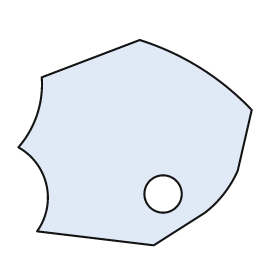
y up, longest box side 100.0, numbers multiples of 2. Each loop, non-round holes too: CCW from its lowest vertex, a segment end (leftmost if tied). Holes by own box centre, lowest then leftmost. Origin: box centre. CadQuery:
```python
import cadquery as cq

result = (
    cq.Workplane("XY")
    .moveTo(8.0, -44.0)
    .lineTo(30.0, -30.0)
    .threePointArc((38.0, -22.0), (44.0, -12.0))
    .lineTo(50.0, 14.0)
    .threePointArc((28.0, 32.0), (2.0, 44.0))
    .lineTo(-40.0, 28.0)
    .threePointArc((-42.0, 12.0), (-50.0, -2.0))
    .threePointArc((-38.0, -18.0), (-42.0, -38.0))
    .close()
    .moveTo(12.0, -22.0)
    .circle(8.0)
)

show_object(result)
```